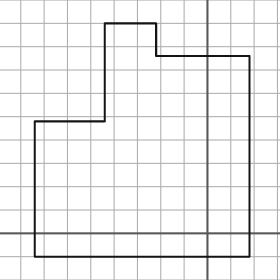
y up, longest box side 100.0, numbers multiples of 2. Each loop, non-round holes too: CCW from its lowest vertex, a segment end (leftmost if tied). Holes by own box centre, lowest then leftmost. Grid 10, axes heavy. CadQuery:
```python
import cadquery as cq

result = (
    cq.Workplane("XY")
    .moveTo(-74.0, -10.0)
    .lineTo(18.0, -10.0)
    .lineTo(18.0, 76.0)
    .lineTo(-22.0, 76.0)
    .lineTo(-22.0, 90.0)
    .lineTo(-44.0, 90.0)
    .lineTo(-44.0, 48.0)
    .lineTo(-74.0, 48.0)
    .close()
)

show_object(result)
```